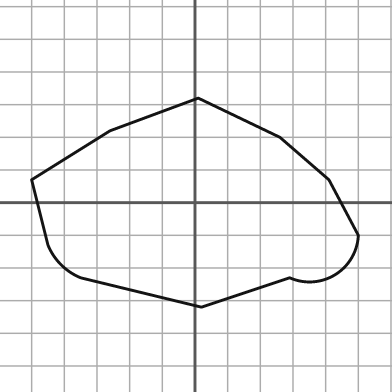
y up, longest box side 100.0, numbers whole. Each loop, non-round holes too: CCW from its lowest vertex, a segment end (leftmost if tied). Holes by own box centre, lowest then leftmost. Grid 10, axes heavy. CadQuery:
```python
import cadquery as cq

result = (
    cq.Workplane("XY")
    .moveTo(2.0, -32.0)
    .lineTo(29.0, -23.0)
    .threePointArc((43.0, -22.0), (50.0, -10.0))
    .lineTo(41.0, 7.0)
    .lineTo(26.0, 20.0)
    .lineTo(1.0, 32.0)
    .lineTo(-26.0, 22.0)
    .lineTo(-50.0, 7.0)
    .lineTo(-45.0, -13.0)
    .threePointArc((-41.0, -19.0), (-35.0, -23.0))
    .close()
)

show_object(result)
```